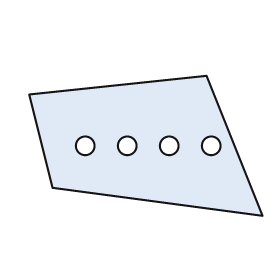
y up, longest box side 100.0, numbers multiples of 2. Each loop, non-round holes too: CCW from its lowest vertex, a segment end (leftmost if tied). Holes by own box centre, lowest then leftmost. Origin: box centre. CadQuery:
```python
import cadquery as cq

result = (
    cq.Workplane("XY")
    .moveTo(50.0, -30.0)
    .lineTo(26.0, 30.0)
    .lineTo(-50.0, 22.0)
    .lineTo(-40.0, -18.0)
    .close()
    .moveTo(-26.0, 0.0)
    .circle(4.0)
    .moveTo(-8.0, 0.0)
    .circle(4.0)
    .moveTo(10.0, 0.0)
    .circle(4.0)
    .moveTo(28.0, 0.0)
    .circle(4.0)
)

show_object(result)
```